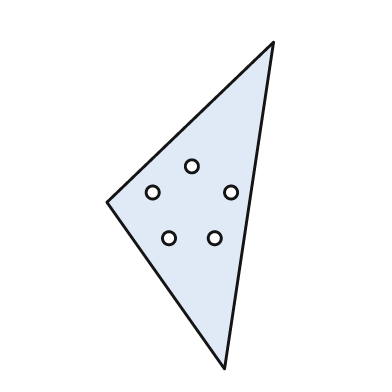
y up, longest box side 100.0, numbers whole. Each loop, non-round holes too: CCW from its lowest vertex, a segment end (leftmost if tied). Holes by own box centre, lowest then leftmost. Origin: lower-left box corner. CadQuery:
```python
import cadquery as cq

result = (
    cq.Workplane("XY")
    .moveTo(36.0, 0.0)
    .lineTo(51.0, 100.0)
    .lineTo(0.0, 51.0)
    .close()
    .moveTo(19.0, 40.0)
    .circle(2.0)
    .moveTo(33.0, 40.0)
    .circle(2.0)
    .moveTo(14.0, 54.0)
    .circle(2.0)
    .moveTo(38.0, 54.0)
    .circle(2.0)
    .moveTo(26.0, 62.0)
    .circle(2.0)
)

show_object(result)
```